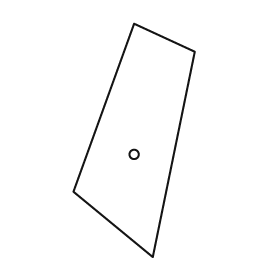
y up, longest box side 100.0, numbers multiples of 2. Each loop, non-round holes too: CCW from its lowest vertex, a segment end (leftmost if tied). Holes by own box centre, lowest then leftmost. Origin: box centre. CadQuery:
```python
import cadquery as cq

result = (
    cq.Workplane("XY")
    .moveTo(8.0, -50.0)
    .lineTo(26.0, 38.0)
    .lineTo(0.0, 50.0)
    .lineTo(-26.0, -22.0)
    .close()
    .moveTo(0.0, -6.0)
    .circle(2.0)
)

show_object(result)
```